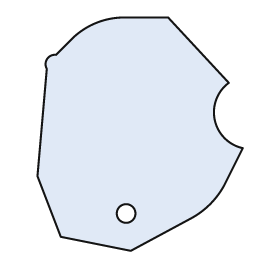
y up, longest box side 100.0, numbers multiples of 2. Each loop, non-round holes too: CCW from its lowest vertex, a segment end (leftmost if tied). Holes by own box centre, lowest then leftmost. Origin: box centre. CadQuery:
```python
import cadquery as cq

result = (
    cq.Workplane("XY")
    .moveTo(-4.0, -50.0)
    .lineTo(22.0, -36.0)
    .threePointArc((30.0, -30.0), (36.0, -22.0))
    .lineTo(44.0, -6.0)
    .threePointArc((32.0, 6.0), (38.0, 22.0))
    .lineTo(12.0, 50.0)
    .lineTo(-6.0, 50.0)
    .threePointArc((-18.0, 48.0), (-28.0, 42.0))
    .lineTo(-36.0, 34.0)
    .threePointArc((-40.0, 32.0), (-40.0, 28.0))
    .lineTo(-44.0, -18.0)
    .lineTo(-34.0, -44.0)
    .close()
    .moveTo(-6.0, -34.0)
    .circle(4.0)
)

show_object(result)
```